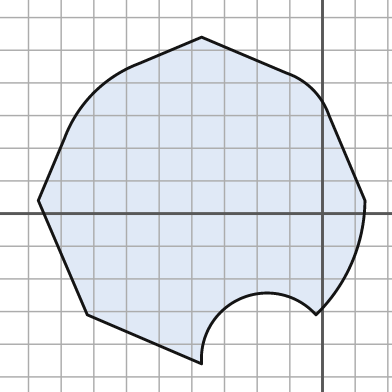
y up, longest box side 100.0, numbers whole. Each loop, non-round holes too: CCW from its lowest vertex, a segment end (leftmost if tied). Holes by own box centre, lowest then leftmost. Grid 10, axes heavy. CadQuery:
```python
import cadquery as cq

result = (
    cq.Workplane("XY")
    .moveTo(-37.0, -46.0)
    .threePointArc((-25.0, -26.0), (-2.0, -31.0))
    .threePointArc((9.0, -15.0), (13.0, 4.0))
    .lineTo(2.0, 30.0)
    .threePointArc((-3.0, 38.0), (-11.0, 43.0))
    .lineTo(-37.0, 54.0)
    .lineTo(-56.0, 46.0)
    .threePointArc((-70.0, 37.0), (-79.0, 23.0))
    .lineTo(-87.0, 4.0)
    .lineTo(-72.0, -31.0)
    .close()
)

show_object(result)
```